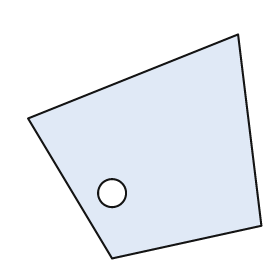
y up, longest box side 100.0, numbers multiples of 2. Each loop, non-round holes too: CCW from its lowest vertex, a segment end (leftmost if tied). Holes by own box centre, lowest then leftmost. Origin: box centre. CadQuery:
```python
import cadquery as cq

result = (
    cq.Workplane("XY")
    .moveTo(-14.0, -48.0)
    .lineTo(50.0, -34.0)
    .lineTo(40.0, 48.0)
    .lineTo(-50.0, 12.0)
    .close()
    .moveTo(-14.0, -20.0)
    .circle(6.0)
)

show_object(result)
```